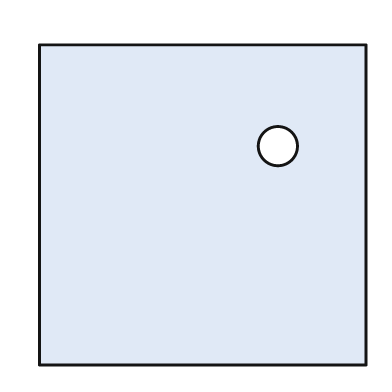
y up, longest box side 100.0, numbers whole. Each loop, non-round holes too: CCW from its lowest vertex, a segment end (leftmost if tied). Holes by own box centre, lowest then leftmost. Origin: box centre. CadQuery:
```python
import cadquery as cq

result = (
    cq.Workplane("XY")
    .moveTo(-50.0, -49.0)
    .lineTo(50.0, -49.0)
    .lineTo(50.0, 49.0)
    .lineTo(-50.0, 49.0)
    .close()
    .moveTo(23.0, 18.0)
    .circle(6.0)
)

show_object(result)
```